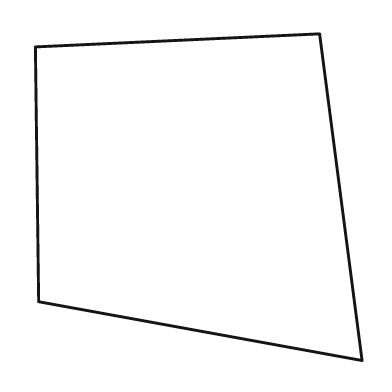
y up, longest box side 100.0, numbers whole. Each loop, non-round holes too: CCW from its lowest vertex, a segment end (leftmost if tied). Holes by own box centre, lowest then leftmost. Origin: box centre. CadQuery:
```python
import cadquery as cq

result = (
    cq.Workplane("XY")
    .moveTo(50.0, -50.0)
    .lineTo(37.0, 50.0)
    .lineTo(-50.0, 46.0)
    .lineTo(-49.0, -32.0)
    .close()
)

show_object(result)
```